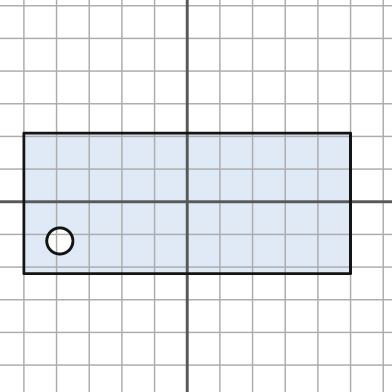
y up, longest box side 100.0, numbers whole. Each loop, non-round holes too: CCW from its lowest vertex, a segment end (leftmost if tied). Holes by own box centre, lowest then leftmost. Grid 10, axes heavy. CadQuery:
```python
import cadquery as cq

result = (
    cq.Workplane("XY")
    .moveTo(-50.0, -22.0)
    .lineTo(50.0, -22.0)
    .lineTo(50.0, 21.0)
    .lineTo(-50.0, 21.0)
    .close()
    .moveTo(-39.0, -12.0)
    .circle(4.0)
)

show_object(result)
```